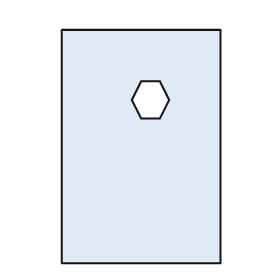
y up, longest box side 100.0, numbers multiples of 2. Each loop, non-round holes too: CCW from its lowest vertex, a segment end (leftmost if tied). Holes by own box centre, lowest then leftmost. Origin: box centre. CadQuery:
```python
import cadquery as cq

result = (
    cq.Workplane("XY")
    .moveTo(-34.0, -50.0)
    .lineTo(34.0, -50.0)
    .lineTo(34.0, 50.0)
    .lineTo(-34.0, 50.0)
    .close()
    .moveTo(0.0, 12.0)
    .lineTo(8.0, 12.0)
    .lineTo(12.0, 20.0)
    .lineTo(8.0, 28.0)
    .lineTo(0.0, 28.0)
    .lineTo(-4.0, 20.0)
    .close()
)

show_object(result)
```